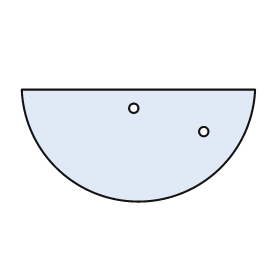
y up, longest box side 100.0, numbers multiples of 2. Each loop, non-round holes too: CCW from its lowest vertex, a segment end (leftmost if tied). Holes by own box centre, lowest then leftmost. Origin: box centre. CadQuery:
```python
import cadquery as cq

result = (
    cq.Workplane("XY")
    .moveTo(-50.0, 24.0)
    .threePointArc((0.0, -24.0), (50.0, 24.0))
    .close()
    .moveTo(28.0, 6.0)
    .circle(2.0)
    .moveTo(-2.0, 16.0)
    .circle(2.0)
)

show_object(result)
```